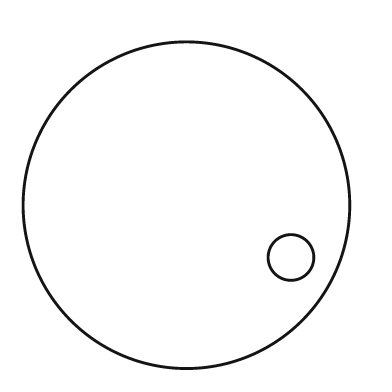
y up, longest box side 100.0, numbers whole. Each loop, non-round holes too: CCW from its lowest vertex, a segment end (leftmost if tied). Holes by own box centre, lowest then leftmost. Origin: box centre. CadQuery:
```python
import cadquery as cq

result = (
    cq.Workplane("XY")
    .moveTo(0.0, 0.0)
    .circle(50.0)
    .moveTo(32.0, -16.0)
    .circle(7.0)
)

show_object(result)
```